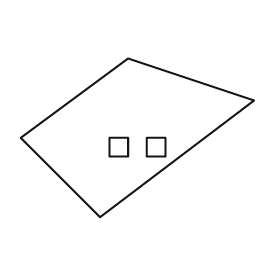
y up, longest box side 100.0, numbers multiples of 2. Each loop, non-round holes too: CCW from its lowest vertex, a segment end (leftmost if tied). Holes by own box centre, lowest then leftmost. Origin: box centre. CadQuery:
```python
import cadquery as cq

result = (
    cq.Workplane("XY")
    .moveTo(-16.0, -34.0)
    .lineTo(50.0, 16.0)
    .lineTo(-4.0, 34.0)
    .lineTo(-50.0, 0.0)
    .close()
    .moveTo(-12.0, -8.0)
    .lineTo(-4.0, -8.0)
    .lineTo(-4.0, 0.0)
    .lineTo(-12.0, 0.0)
    .close()
    .moveTo(4.0, -8.0)
    .lineTo(12.0, -8.0)
    .lineTo(12.0, 0.0)
    .lineTo(4.0, 0.0)
    .close()
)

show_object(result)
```